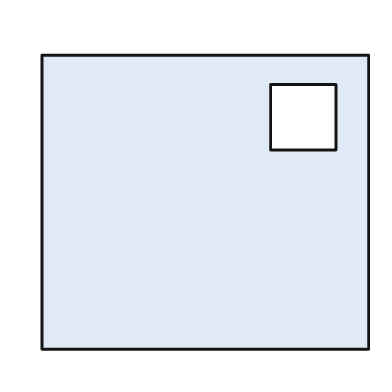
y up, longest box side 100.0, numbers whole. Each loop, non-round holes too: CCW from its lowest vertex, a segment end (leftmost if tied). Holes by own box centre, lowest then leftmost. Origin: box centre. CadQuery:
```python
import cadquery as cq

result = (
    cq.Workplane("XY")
    .moveTo(-50.0, -45.0)
    .lineTo(50.0, -45.0)
    .lineTo(50.0, 45.0)
    .lineTo(-50.0, 45.0)
    .close()
    .moveTo(20.0, 16.0)
    .lineTo(40.0, 16.0)
    .lineTo(40.0, 36.0)
    .lineTo(20.0, 36.0)
    .close()
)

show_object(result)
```